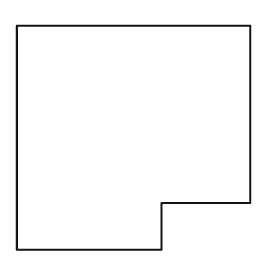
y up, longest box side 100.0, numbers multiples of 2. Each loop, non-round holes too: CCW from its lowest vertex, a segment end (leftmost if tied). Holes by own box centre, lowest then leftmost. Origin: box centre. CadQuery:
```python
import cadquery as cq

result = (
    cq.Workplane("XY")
    .moveTo(-50.0, -48.0)
    .lineTo(12.0, -48.0)
    .lineTo(12.0, -28.0)
    .lineTo(50.0, -28.0)
    .lineTo(50.0, 48.0)
    .lineTo(-50.0, 48.0)
    .close()
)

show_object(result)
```